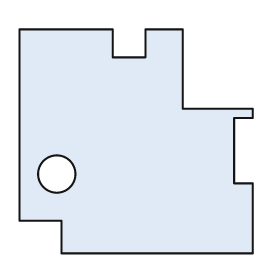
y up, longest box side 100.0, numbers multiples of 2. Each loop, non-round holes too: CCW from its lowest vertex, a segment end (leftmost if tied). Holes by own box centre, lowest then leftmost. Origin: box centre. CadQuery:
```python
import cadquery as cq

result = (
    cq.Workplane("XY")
    .moveTo(-32.0, -48.0)
    .lineTo(50.0, -48.0)
    .lineTo(50.0, -18.0)
    .lineTo(42.0, -18.0)
    .lineTo(42.0, 10.0)
    .lineTo(50.0, 10.0)
    .lineTo(50.0, 14.0)
    .lineTo(20.0, 14.0)
    .lineTo(20.0, 48.0)
    .lineTo(4.0, 48.0)
    .lineTo(4.0, 36.0)
    .lineTo(-10.0, 36.0)
    .lineTo(-10.0, 48.0)
    .lineTo(-50.0, 48.0)
    .lineTo(-50.0, -34.0)
    .lineTo(-32.0, -34.0)
    .close()
    .moveTo(-34.0, -14.0)
    .circle(8.0)
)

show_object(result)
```